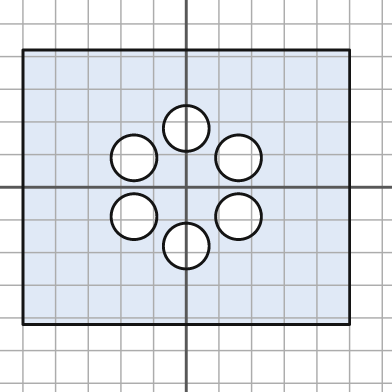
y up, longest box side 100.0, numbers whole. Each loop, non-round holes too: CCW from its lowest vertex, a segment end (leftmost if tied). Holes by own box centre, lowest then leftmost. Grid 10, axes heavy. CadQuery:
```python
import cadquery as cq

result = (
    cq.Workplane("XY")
    .moveTo(-50.0, -42.0)
    .lineTo(50.0, -42.0)
    .lineTo(50.0, 42.0)
    .lineTo(-50.0, 42.0)
    .close()
    .moveTo(0.0, -18.0)
    .circle(7.0)
    .moveTo(-16.0, -9.0)
    .circle(7.0)
    .moveTo(16.0, -9.0)
    .circle(7.0)
    .moveTo(-16.0, 9.0)
    .circle(7.0)
    .moveTo(16.0, 9.0)
    .circle(7.0)
    .moveTo(0.0, 18.0)
    .circle(7.0)
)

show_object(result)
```